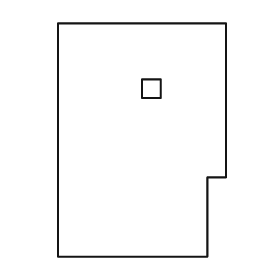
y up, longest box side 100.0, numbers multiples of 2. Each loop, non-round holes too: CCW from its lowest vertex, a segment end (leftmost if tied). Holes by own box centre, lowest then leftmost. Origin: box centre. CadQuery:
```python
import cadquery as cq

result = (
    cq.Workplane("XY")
    .moveTo(-36.0, -50.0)
    .lineTo(28.0, -50.0)
    .lineTo(28.0, -16.0)
    .lineTo(36.0, -16.0)
    .lineTo(36.0, 50.0)
    .lineTo(-36.0, 50.0)
    .close()
    .moveTo(0.0, 18.0)
    .lineTo(8.0, 18.0)
    .lineTo(8.0, 26.0)
    .lineTo(0.0, 26.0)
    .close()
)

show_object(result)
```